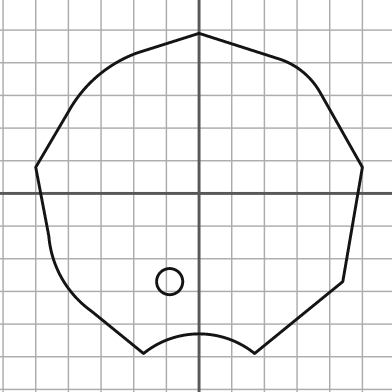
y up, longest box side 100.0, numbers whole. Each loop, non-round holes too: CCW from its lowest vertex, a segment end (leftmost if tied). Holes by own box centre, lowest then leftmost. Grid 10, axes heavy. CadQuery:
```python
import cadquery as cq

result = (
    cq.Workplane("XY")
    .moveTo(-17.0, -49.0)
    .threePointArc((0.0, -43.0), (17.0, -49.0))
    .lineTo(44.0, -27.0)
    .lineTo(50.0, 8.0)
    .lineTo(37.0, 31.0)
    .threePointArc((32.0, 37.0), (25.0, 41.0))
    .lineTo(0.0, 49.0)
    .lineTo(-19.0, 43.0)
    .threePointArc((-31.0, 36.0), (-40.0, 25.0))
    .lineTo(-50.0, 8.0)
    .lineTo(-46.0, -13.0)
    .threePointArc((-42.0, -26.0), (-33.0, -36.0))
    .close()
    .moveTo(-9.0, -27.0)
    .circle(4.0)
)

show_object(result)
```